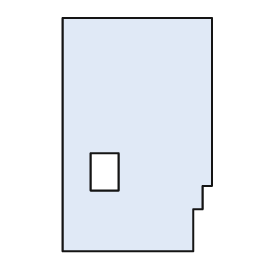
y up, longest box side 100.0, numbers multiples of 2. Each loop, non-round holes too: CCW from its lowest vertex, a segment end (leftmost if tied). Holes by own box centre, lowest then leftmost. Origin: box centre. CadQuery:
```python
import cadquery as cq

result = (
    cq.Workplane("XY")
    .moveTo(-32.0, -50.0)
    .lineTo(24.0, -50.0)
    .lineTo(24.0, -32.0)
    .lineTo(28.0, -32.0)
    .lineTo(28.0, -22.0)
    .lineTo(32.0, -22.0)
    .lineTo(32.0, 50.0)
    .lineTo(-32.0, 50.0)
    .close()
    .moveTo(-20.0, -24.0)
    .lineTo(-8.0, -24.0)
    .lineTo(-8.0, -8.0)
    .lineTo(-20.0, -8.0)
    .close()
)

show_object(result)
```